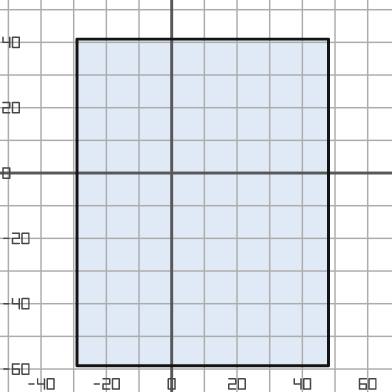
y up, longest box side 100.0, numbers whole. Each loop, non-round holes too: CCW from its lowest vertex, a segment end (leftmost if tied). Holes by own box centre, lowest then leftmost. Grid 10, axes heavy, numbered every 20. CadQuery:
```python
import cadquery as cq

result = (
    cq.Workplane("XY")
    .moveTo(-29.0, -59.0)
    .lineTo(48.0, -59.0)
    .lineTo(48.0, 41.0)
    .lineTo(-29.0, 41.0)
    .close()
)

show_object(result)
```